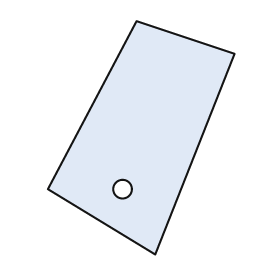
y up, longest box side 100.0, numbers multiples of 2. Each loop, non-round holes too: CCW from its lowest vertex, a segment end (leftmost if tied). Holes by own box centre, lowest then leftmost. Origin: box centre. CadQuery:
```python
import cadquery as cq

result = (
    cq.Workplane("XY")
    .moveTo(6.0, -50.0)
    .lineTo(40.0, 36.0)
    .lineTo(-2.0, 50.0)
    .lineTo(-40.0, -22.0)
    .close()
    .moveTo(-8.0, -22.0)
    .circle(4.0)
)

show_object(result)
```